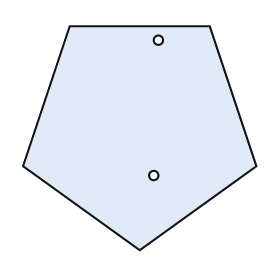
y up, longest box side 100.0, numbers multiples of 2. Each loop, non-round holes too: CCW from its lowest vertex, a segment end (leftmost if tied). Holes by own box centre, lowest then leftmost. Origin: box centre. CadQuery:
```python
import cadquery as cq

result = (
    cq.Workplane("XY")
    .moveTo(0.0, -48.0)
    .lineTo(50.0, -12.0)
    .lineTo(30.0, 48.0)
    .lineTo(-30.0, 48.0)
    .lineTo(-50.0, -12.0)
    .close()
    .moveTo(6.0, -16.0)
    .circle(2.0)
    .moveTo(8.0, 42.0)
    .circle(2.0)
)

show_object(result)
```